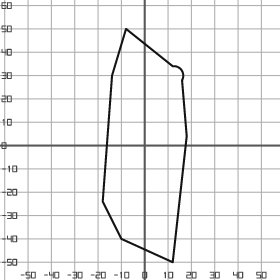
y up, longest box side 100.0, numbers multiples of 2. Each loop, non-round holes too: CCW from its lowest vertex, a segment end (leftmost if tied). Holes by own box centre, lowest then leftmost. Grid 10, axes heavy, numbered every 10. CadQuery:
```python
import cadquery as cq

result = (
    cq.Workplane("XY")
    .moveTo(12.0, -50.0)
    .lineTo(18.0, 4.0)
    .lineTo(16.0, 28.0)
    .threePointArc((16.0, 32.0), (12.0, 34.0))
    .lineTo(-8.0, 50.0)
    .lineTo(-14.0, 30.0)
    .lineTo(-18.0, -24.0)
    .lineTo(-10.0, -40.0)
    .close()
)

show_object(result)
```